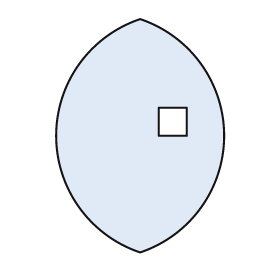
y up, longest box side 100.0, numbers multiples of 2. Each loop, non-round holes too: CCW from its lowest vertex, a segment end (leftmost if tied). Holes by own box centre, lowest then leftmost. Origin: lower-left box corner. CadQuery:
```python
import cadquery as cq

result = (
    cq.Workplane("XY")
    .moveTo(36.0, 0.0)
    .threePointArc((72.0, 50.0), (36.0, 100.0))
    .threePointArc((0.0, 50.0), (36.0, 0.0))
    .close()
    .moveTo(44.0, 50.0)
    .lineTo(56.0, 50.0)
    .lineTo(56.0, 62.0)
    .lineTo(44.0, 62.0)
    .close()
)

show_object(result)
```